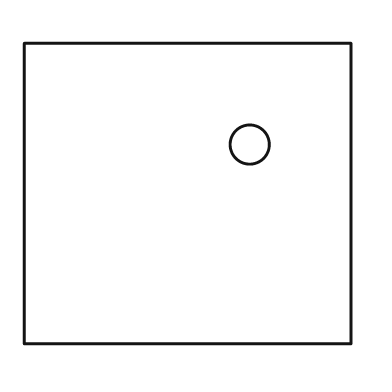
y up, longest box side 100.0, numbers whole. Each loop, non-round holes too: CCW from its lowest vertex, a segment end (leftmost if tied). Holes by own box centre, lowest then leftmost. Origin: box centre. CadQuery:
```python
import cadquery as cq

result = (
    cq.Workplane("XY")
    .moveTo(-50.0, -46.0)
    .lineTo(50.0, -46.0)
    .lineTo(50.0, 46.0)
    .lineTo(-50.0, 46.0)
    .close()
    .moveTo(19.0, 15.0)
    .circle(6.0)
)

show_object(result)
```